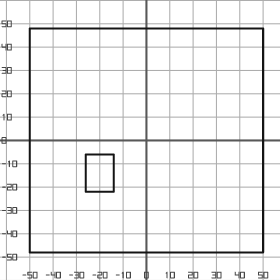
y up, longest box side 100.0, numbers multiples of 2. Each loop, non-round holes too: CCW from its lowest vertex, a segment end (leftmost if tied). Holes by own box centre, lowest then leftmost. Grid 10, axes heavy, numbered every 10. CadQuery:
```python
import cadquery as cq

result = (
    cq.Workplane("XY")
    .moveTo(-50.0, -48.0)
    .lineTo(50.0, -48.0)
    .lineTo(50.0, 48.0)
    .lineTo(-50.0, 48.0)
    .close()
    .moveTo(-26.0, -22.0)
    .lineTo(-14.0, -22.0)
    .lineTo(-14.0, -6.0)
    .lineTo(-26.0, -6.0)
    .close()
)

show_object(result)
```